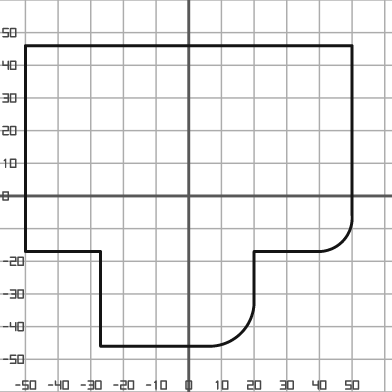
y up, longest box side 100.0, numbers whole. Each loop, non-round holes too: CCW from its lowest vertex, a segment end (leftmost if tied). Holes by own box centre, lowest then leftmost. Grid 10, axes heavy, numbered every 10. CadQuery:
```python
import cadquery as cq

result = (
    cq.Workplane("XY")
    .moveTo(-27.0, -46.0)
    .lineTo(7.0, -46.0)
    .threePointArc((16.0, -42.0), (20.0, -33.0))
    .lineTo(20.0, -17.0)
    .lineTo(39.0, -17.0)
    .threePointArc((47.0, -14.0), (50.0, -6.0))
    .lineTo(50.0, 46.0)
    .lineTo(-50.0, 46.0)
    .lineTo(-50.0, -17.0)
    .lineTo(-27.0, -17.0)
    .close()
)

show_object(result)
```